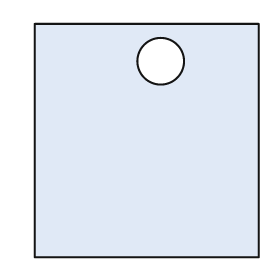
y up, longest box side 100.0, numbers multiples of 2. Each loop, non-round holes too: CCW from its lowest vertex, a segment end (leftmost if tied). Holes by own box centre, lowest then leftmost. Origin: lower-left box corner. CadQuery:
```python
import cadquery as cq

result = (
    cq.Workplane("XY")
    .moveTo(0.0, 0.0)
    .lineTo(96.0, 0.0)
    .lineTo(96.0, 100.0)
    .lineTo(0.0, 100.0)
    .close()
    .moveTo(54.0, 84.0)
    .circle(10.0)
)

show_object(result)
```